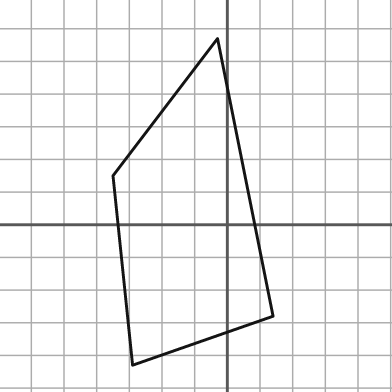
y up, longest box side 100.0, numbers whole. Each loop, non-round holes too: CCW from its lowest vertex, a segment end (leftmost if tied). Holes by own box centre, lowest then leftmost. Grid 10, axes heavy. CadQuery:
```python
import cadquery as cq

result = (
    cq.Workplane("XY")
    .moveTo(-29.0, -43.0)
    .lineTo(14.0, -28.0)
    .lineTo(-3.0, 57.0)
    .lineTo(-35.0, 15.0)
    .close()
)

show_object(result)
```